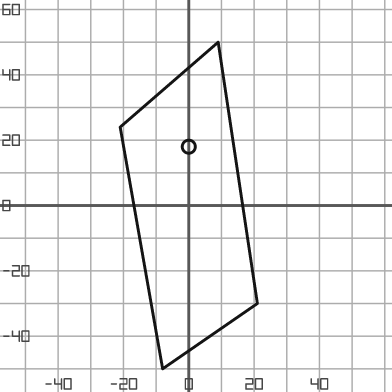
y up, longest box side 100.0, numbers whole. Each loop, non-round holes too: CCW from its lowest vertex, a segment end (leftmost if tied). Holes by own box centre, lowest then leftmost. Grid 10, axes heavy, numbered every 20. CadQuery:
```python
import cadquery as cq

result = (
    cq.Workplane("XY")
    .moveTo(-8.0, -50.0)
    .lineTo(21.0, -30.0)
    .lineTo(9.0, 50.0)
    .lineTo(-21.0, 24.0)
    .close()
    .moveTo(0.0, 18.0)
    .circle(2.0)
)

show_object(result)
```